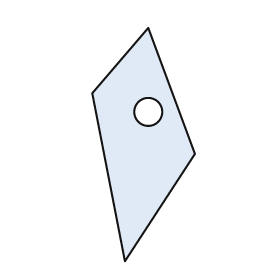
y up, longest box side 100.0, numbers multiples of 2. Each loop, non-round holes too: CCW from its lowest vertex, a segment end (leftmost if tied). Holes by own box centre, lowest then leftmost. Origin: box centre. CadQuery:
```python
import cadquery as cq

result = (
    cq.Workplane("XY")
    .moveTo(-8.0, -50.0)
    .lineTo(22.0, -4.0)
    .lineTo(2.0, 50.0)
    .lineTo(-22.0, 22.0)
    .close()
    .moveTo(2.0, 14.0)
    .circle(6.0)
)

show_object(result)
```